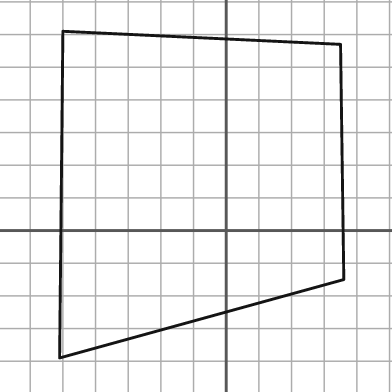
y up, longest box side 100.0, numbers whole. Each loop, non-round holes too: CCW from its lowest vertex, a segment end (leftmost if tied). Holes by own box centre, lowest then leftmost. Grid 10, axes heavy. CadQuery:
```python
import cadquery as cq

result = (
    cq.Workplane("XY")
    .moveTo(-51.0, -39.0)
    .lineTo(36.0, -15.0)
    .lineTo(35.0, 57.0)
    .lineTo(-50.0, 61.0)
    .close()
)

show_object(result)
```